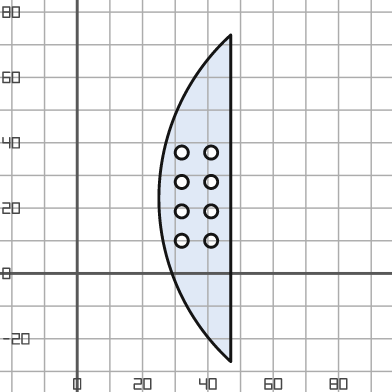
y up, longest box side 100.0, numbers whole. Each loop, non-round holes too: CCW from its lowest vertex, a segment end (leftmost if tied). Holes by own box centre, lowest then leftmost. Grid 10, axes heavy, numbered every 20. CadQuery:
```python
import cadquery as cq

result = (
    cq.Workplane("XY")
    .moveTo(47.0, -27.0)
    .lineTo(47.0, 73.0)
    .threePointArc((25.0, 23.0), (47.0, -27.0))
    .close()
    .moveTo(32.0, 10.0)
    .circle(2.0)
    .moveTo(41.0, 10.0)
    .circle(2.0)
    .moveTo(32.0, 19.0)
    .circle(2.0)
    .moveTo(41.0, 19.0)
    .circle(2.0)
    .moveTo(32.0, 28.0)
    .circle(2.0)
    .moveTo(41.0, 28.0)
    .circle(2.0)
    .moveTo(32.0, 37.0)
    .circle(2.0)
    .moveTo(41.0, 37.0)
    .circle(2.0)
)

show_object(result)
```